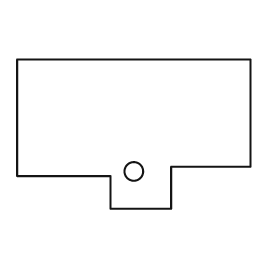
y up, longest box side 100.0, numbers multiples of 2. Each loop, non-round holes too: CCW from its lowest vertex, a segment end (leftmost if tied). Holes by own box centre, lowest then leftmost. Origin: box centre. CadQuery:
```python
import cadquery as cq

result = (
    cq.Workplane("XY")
    .moveTo(-10.0, -32.0)
    .lineTo(16.0, -32.0)
    .lineTo(16.0, -14.0)
    .lineTo(50.0, -14.0)
    .lineTo(50.0, 32.0)
    .lineTo(-50.0, 32.0)
    .lineTo(-50.0, -18.0)
    .lineTo(-10.0, -18.0)
    .close()
    .moveTo(0.0, -16.0)
    .circle(4.0)
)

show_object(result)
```